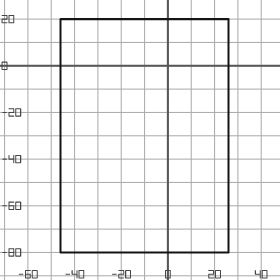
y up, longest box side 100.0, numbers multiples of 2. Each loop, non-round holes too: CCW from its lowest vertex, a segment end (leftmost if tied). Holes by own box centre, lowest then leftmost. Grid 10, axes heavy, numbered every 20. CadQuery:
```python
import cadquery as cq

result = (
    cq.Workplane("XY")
    .moveTo(-46.0, -80.0)
    .lineTo(26.0, -80.0)
    .lineTo(26.0, 20.0)
    .lineTo(-46.0, 20.0)
    .close()
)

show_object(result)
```